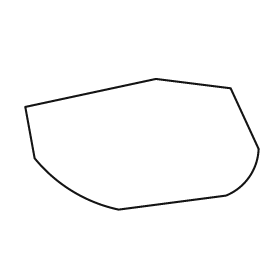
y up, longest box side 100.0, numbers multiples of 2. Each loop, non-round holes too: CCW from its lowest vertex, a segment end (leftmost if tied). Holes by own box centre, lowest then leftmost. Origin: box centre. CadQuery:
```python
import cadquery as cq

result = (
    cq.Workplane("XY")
    .moveTo(-10.0, -28.0)
    .lineTo(36.0, -22.0)
    .threePointArc((46.0, -14.0), (50.0, -2.0))
    .lineTo(38.0, 24.0)
    .lineTo(6.0, 28.0)
    .lineTo(-50.0, 16.0)
    .lineTo(-46.0, -6.0)
    .threePointArc((-30.0, -20.0), (-10.0, -28.0))
    .close()
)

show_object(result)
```